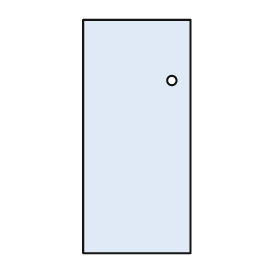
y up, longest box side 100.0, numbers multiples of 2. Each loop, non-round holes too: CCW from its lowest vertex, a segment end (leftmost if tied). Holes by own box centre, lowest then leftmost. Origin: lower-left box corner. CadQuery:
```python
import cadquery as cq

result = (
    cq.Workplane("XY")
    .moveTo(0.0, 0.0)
    .lineTo(46.0, 0.0)
    .lineTo(46.0, 100.0)
    .lineTo(0.0, 100.0)
    .close()
    .moveTo(38.0, 74.0)
    .circle(2.0)
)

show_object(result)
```